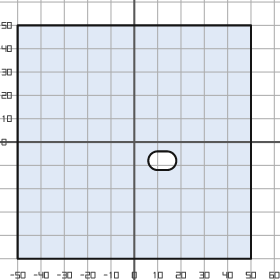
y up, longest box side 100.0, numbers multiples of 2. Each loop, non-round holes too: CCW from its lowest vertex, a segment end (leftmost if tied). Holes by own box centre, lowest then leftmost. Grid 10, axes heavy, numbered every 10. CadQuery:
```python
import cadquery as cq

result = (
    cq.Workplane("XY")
    .moveTo(-50.0, -50.0)
    .lineTo(50.0, -50.0)
    .lineTo(50.0, 50.0)
    .lineTo(-50.0, 50.0)
    .close()
    .moveTo(10.0, -12.0)
    .lineTo(14.0, -12.0)
    .threePointArc((18.0, -8.0), (14.0, -4.0))
    .lineTo(10.0, -4.0)
    .threePointArc((6.0, -8.0), (10.0, -12.0))
    .close()
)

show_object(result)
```